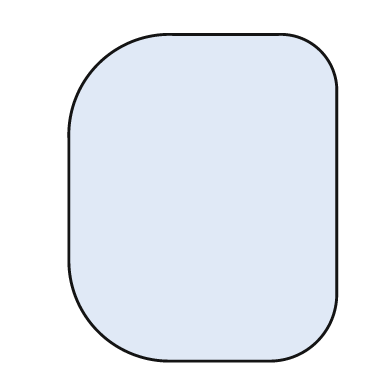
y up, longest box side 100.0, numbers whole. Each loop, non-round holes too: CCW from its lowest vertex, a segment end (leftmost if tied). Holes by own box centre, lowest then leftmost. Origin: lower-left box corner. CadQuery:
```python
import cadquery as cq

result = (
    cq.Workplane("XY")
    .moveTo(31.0, 0.0)
    .lineTo(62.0, 0.0)
    .threePointArc((76.0, 6.0), (82.0, 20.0))
    .lineTo(82.0, 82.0)
    .threePointArc((77.0, 95.0), (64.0, 100.0))
    .lineTo(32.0, 100.0)
    .threePointArc((9.0, 91.0), (0.0, 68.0))
    .lineTo(0.0, 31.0)
    .threePointArc((9.0, 9.0), (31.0, 0.0))
    .close()
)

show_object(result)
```